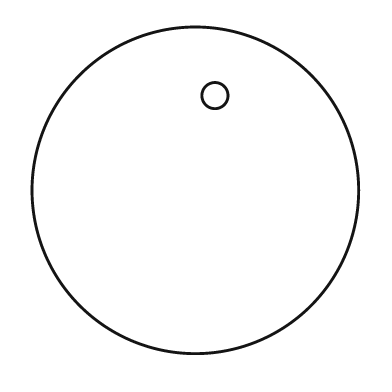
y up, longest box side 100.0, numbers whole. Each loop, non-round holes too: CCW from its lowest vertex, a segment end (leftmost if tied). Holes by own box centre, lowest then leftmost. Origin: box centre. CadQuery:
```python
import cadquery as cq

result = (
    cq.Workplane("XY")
    .moveTo(0.0, 0.0)
    .circle(50.0)
    .moveTo(6.0, 29.0)
    .circle(4.0)
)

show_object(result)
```